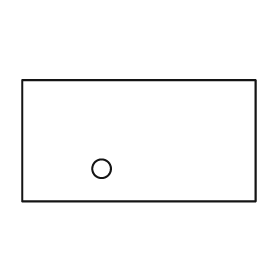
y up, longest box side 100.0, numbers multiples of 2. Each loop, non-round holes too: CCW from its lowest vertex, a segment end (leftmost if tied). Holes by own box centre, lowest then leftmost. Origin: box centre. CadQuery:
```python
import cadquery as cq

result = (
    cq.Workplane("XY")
    .moveTo(-50.0, -26.0)
    .lineTo(50.0, -26.0)
    .lineTo(50.0, 26.0)
    .lineTo(-50.0, 26.0)
    .close()
    .moveTo(-16.0, -12.0)
    .circle(4.0)
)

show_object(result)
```